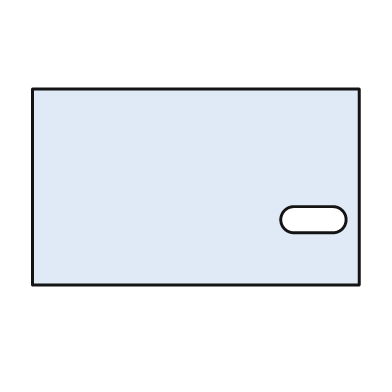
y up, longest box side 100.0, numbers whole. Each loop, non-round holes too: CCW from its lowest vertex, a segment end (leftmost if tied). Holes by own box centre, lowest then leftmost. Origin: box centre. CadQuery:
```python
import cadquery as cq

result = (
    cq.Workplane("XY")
    .moveTo(-50.0, -30.0)
    .lineTo(50.0, -30.0)
    .lineTo(50.0, 30.0)
    .lineTo(-50.0, 30.0)
    .close()
    .moveTo(30.0, -14.0)
    .lineTo(42.0, -14.0)
    .threePointArc((46.0, -10.0), (42.0, -6.0))
    .lineTo(30.0, -6.0)
    .threePointArc((26.0, -10.0), (30.0, -14.0))
    .close()
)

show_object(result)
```